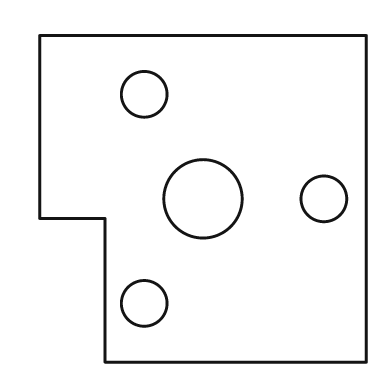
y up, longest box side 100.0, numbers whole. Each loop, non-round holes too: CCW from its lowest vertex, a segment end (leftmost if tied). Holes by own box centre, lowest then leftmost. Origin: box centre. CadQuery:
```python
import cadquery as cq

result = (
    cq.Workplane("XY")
    .moveTo(-30.0, -50.0)
    .lineTo(50.0, -50.0)
    .lineTo(50.0, 50.0)
    .lineTo(-50.0, 50.0)
    .lineTo(-50.0, -6.0)
    .lineTo(-30.0, -6.0)
    .close()
    .moveTo(-18.0, -32.0)
    .circle(7.0)
    .moveTo(0.0, 0.0)
    .circle(12.0)
    .moveTo(37.0, 0.0)
    .circle(7.0)
    .moveTo(-18.0, 32.0)
    .circle(7.0)
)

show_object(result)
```